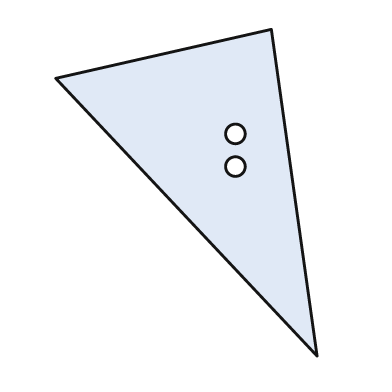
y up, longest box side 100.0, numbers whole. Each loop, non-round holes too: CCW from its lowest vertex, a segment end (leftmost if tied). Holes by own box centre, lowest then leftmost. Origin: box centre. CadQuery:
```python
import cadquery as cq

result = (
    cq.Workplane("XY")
    .moveTo(40.0, -50.0)
    .lineTo(26.0, 50.0)
    .lineTo(-40.0, 35.0)
    .close()
    .moveTo(15.0, 8.0)
    .circle(3.0)
    .moveTo(15.0, 18.0)
    .circle(3.0)
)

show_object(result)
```